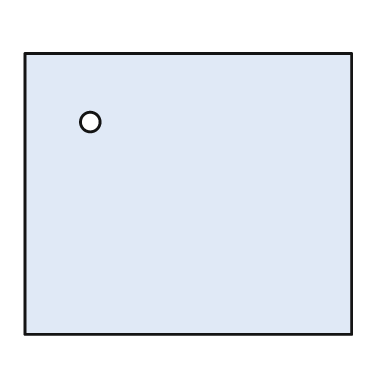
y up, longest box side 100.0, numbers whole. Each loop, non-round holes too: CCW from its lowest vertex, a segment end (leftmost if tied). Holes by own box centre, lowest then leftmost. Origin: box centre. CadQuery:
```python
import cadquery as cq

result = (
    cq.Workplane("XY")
    .moveTo(-50.0, -43.0)
    .lineTo(50.0, -43.0)
    .lineTo(50.0, 43.0)
    .lineTo(-50.0, 43.0)
    .close()
    .moveTo(-30.0, 22.0)
    .circle(3.0)
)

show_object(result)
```